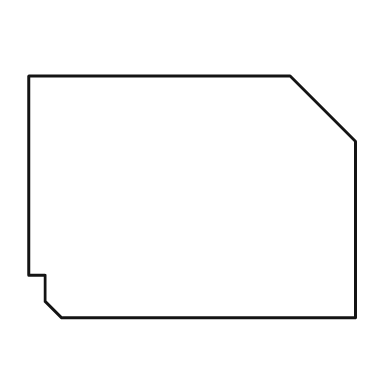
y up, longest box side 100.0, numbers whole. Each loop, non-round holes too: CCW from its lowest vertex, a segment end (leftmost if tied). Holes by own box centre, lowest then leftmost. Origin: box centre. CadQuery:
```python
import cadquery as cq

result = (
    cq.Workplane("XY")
    .moveTo(-40.0, -37.0)
    .lineTo(50.0, -37.0)
    .lineTo(50.0, 17.0)
    .lineTo(30.0, 37.0)
    .lineTo(-50.0, 37.0)
    .lineTo(-50.0, -24.0)
    .lineTo(-45.0, -24.0)
    .lineTo(-45.0, -32.0)
    .close()
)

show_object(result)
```